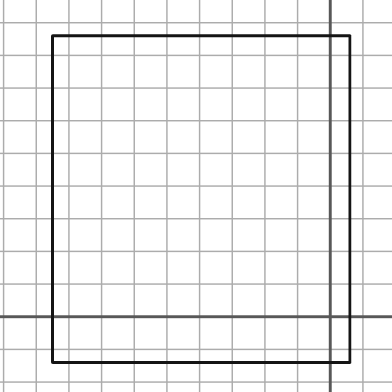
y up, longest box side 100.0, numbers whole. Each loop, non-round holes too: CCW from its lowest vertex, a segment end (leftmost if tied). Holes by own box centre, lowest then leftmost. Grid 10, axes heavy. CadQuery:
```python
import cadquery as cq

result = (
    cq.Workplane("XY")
    .moveTo(-85.0, -14.0)
    .lineTo(6.0, -14.0)
    .lineTo(6.0, 86.0)
    .lineTo(-85.0, 86.0)
    .close()
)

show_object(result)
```